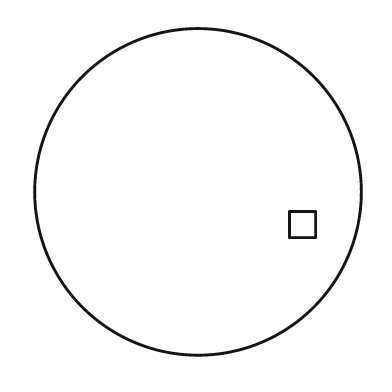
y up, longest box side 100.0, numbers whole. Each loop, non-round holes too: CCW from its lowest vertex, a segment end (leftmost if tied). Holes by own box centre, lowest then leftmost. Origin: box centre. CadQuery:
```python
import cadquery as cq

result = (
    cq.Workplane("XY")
    .moveTo(0.0, 0.0)
    .circle(50.0)
    .moveTo(28.0, -14.0)
    .lineTo(36.0, -14.0)
    .lineTo(36.0, -6.0)
    .lineTo(28.0, -6.0)
    .close()
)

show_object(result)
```